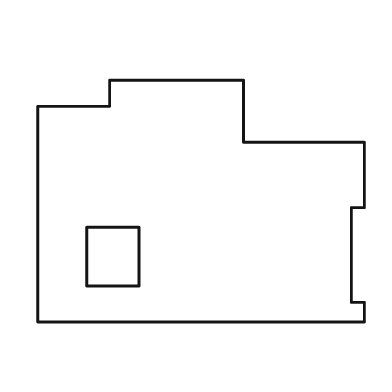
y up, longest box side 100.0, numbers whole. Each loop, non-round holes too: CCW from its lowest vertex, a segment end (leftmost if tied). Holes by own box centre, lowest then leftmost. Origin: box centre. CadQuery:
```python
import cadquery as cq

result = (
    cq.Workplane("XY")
    .moveTo(-50.0, -37.0)
    .lineTo(50.0, -37.0)
    .lineTo(50.0, -31.0)
    .lineTo(46.0, -31.0)
    .lineTo(46.0, -2.0)
    .lineTo(50.0, -2.0)
    .lineTo(50.0, 18.0)
    .lineTo(13.0, 18.0)
    .lineTo(13.0, 37.0)
    .lineTo(-28.0, 37.0)
    .lineTo(-28.0, 29.0)
    .lineTo(-50.0, 29.0)
    .close()
    .moveTo(-35.0, -26.0)
    .lineTo(-19.0, -26.0)
    .lineTo(-19.0, -8.0)
    .lineTo(-35.0, -8.0)
    .close()
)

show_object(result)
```